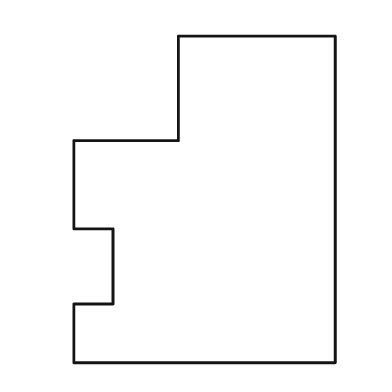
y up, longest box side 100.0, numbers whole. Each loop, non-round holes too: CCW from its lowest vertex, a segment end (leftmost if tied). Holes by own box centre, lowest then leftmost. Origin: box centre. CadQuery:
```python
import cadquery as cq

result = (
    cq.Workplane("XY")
    .moveTo(-40.0, -50.0)
    .lineTo(40.0, -50.0)
    .lineTo(40.0, 50.0)
    .lineTo(-8.0, 50.0)
    .lineTo(-8.0, 18.0)
    .lineTo(-40.0, 18.0)
    .lineTo(-40.0, -9.0)
    .lineTo(-28.0, -9.0)
    .lineTo(-28.0, -32.0)
    .lineTo(-40.0, -32.0)
    .close()
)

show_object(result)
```